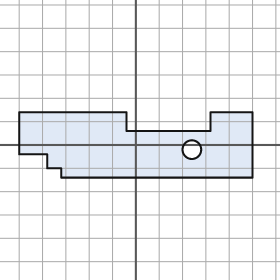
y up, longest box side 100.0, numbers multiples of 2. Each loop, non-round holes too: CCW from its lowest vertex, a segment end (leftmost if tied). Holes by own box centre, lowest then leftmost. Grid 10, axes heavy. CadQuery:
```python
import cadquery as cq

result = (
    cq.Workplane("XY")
    .moveTo(-32.0, -14.0)
    .lineTo(50.0, -14.0)
    .lineTo(50.0, 14.0)
    .lineTo(32.0, 14.0)
    .lineTo(32.0, 6.0)
    .lineTo(-4.0, 6.0)
    .lineTo(-4.0, 14.0)
    .lineTo(-50.0, 14.0)
    .lineTo(-50.0, -4.0)
    .lineTo(-38.0, -4.0)
    .lineTo(-38.0, -10.0)
    .lineTo(-32.0, -10.0)
    .close()
    .moveTo(24.0, -2.0)
    .circle(4.0)
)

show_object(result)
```